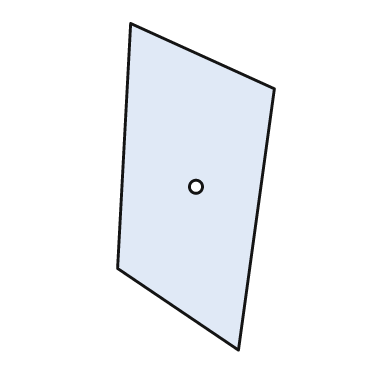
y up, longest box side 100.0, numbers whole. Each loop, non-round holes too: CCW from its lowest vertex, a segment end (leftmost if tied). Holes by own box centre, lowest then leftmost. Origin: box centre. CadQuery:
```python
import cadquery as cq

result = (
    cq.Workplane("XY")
    .moveTo(13.0, -50.0)
    .lineTo(24.0, 30.0)
    .lineTo(-20.0, 50.0)
    .lineTo(-24.0, -25.0)
    .close()
    .moveTo(0.0, 0.0)
    .circle(2.0)
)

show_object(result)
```